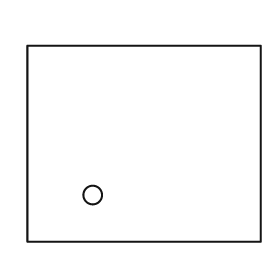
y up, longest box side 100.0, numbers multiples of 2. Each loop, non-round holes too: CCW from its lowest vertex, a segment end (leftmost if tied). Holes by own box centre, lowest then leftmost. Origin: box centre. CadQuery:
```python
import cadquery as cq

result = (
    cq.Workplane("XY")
    .moveTo(-50.0, -42.0)
    .lineTo(50.0, -42.0)
    .lineTo(50.0, 42.0)
    .lineTo(-50.0, 42.0)
    .close()
    .moveTo(-22.0, -22.0)
    .circle(4.0)
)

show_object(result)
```